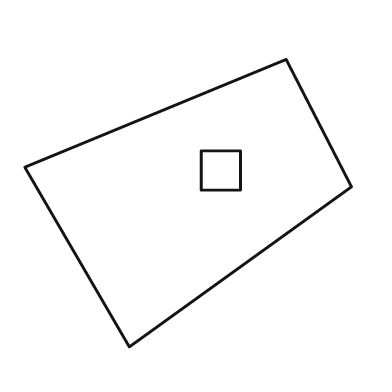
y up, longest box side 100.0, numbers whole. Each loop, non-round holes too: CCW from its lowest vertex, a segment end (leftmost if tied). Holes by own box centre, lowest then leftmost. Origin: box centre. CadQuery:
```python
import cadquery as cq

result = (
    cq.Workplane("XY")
    .moveTo(-18.0, -44.0)
    .lineTo(50.0, 5.0)
    .lineTo(30.0, 44.0)
    .lineTo(-50.0, 11.0)
    .close()
    .moveTo(4.0, 4.0)
    .lineTo(16.0, 4.0)
    .lineTo(16.0, 16.0)
    .lineTo(4.0, 16.0)
    .close()
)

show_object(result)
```